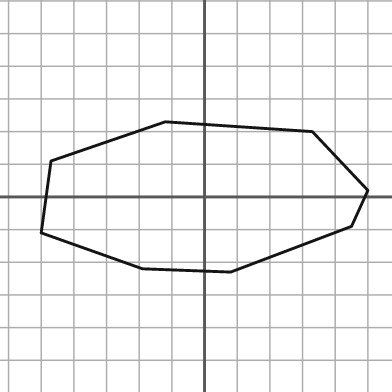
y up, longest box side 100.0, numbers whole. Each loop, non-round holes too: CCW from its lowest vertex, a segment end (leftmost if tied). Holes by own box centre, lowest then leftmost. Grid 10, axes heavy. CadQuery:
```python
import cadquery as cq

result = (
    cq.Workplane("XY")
    .moveTo(8.0, -23.0)
    .lineTo(45.0, -9.0)
    .lineTo(50.0, 2.0)
    .lineTo(33.0, 20.0)
    .lineTo(-12.0, 23.0)
    .lineTo(-47.0, 11.0)
    .lineTo(-50.0, -11.0)
    .lineTo(-19.0, -22.0)
    .close()
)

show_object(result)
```